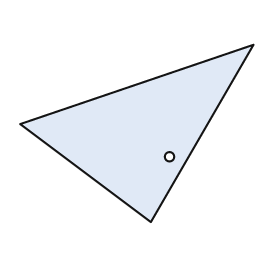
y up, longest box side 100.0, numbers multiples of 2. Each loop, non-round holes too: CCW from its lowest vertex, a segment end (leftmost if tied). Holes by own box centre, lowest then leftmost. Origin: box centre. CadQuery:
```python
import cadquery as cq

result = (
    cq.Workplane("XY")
    .moveTo(6.0, -38.0)
    .lineTo(50.0, 38.0)
    .lineTo(-50.0, 4.0)
    .close()
    .moveTo(14.0, -10.0)
    .circle(2.0)
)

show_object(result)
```